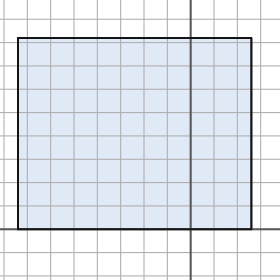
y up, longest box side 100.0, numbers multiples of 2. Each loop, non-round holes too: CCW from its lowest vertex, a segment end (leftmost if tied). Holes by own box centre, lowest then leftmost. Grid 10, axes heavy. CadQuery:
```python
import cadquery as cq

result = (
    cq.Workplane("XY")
    .moveTo(-74.0, 0.0)
    .lineTo(26.0, 0.0)
    .lineTo(26.0, 82.0)
    .lineTo(-74.0, 82.0)
    .close()
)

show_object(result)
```